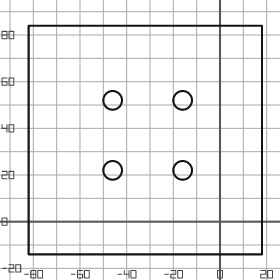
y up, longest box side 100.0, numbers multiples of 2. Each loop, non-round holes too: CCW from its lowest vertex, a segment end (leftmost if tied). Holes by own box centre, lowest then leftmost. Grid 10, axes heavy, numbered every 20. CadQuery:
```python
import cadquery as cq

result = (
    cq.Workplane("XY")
    .moveTo(-82.0, -14.0)
    .lineTo(18.0, -14.0)
    .lineTo(18.0, 84.0)
    .lineTo(-82.0, 84.0)
    .close()
    .moveTo(-46.0, 22.0)
    .circle(4.0)
    .moveTo(-16.0, 22.0)
    .circle(4.0)
    .moveTo(-46.0, 52.0)
    .circle(4.0)
    .moveTo(-16.0, 52.0)
    .circle(4.0)
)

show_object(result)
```